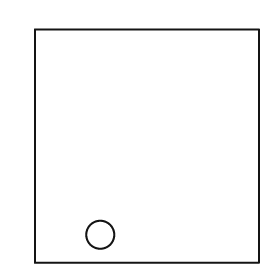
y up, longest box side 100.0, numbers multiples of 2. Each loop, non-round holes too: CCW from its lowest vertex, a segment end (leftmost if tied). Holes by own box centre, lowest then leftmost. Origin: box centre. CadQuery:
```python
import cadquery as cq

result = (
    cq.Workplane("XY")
    .moveTo(-48.0, -50.0)
    .lineTo(48.0, -50.0)
    .lineTo(48.0, 50.0)
    .lineTo(-48.0, 50.0)
    .close()
    .moveTo(-20.0, -38.0)
    .circle(6.0)
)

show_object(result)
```